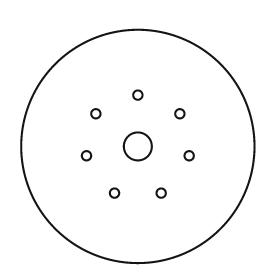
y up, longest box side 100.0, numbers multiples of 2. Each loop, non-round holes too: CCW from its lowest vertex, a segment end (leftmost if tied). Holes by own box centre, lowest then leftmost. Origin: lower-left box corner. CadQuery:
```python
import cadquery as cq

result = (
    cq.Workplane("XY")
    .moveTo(50.0, 50.0)
    .circle(50.0)
    .moveTo(40.0, 30.0)
    .circle(2.0)
    .moveTo(60.0, 30.0)
    .circle(2.0)
    .moveTo(28.0, 46.0)
    .circle(2.0)
    .moveTo(72.0, 46.0)
    .circle(2.0)
    .moveTo(50.0, 50.0)
    .circle(6.0)
    .moveTo(32.0, 64.0)
    .circle(2.0)
    .moveTo(68.0, 64.0)
    .circle(2.0)
    .moveTo(50.0, 72.0)
    .circle(2.0)
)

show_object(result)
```